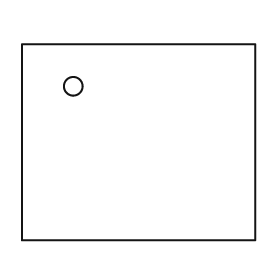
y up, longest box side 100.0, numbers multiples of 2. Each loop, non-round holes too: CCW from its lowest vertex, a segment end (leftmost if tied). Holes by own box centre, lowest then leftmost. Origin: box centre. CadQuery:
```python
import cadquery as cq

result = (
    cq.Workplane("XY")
    .moveTo(-50.0, -42.0)
    .lineTo(50.0, -42.0)
    .lineTo(50.0, 42.0)
    .lineTo(-50.0, 42.0)
    .close()
    .moveTo(-28.0, 24.0)
    .circle(4.0)
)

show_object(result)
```